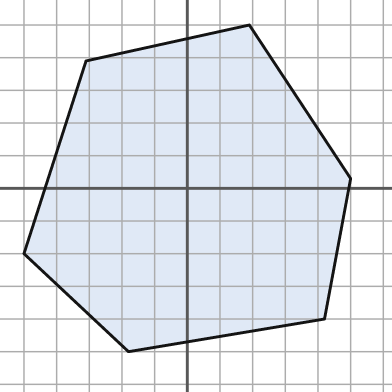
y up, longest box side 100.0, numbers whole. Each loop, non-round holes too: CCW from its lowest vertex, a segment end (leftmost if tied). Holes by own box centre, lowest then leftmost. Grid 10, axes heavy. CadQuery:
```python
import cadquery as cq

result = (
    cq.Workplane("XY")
    .moveTo(-18.0, -50.0)
    .lineTo(42.0, -40.0)
    .lineTo(50.0, 3.0)
    .lineTo(19.0, 50.0)
    .lineTo(-31.0, 39.0)
    .lineTo(-50.0, -20.0)
    .close()
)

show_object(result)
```